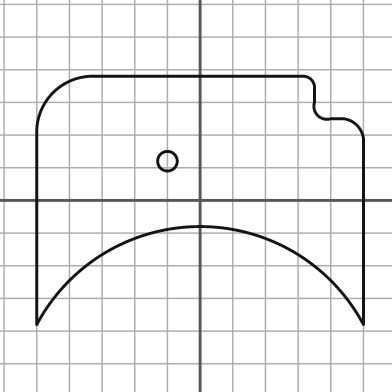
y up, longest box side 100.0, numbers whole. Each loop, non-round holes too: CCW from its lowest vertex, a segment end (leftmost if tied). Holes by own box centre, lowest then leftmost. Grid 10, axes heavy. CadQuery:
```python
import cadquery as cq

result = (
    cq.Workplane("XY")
    .moveTo(-50.0, -38.0)
    .threePointArc((0.0, -8.0), (50.0, -38.0))
    .lineTo(50.0, 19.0)
    .threePointArc((48.0, 23.0), (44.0, 25.0))
    .lineTo(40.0, 25.0)
    .threePointArc((36.0, 26.0), (35.0, 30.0))
    .lineTo(35.0, 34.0)
    .threePointArc((34.0, 37.0), (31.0, 38.0))
    .lineTo(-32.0, 38.0)
    .threePointArc((-45.0, 33.0), (-50.0, 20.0))
    .close()
    .moveTo(-10.0, 12.0)
    .circle(3.0)
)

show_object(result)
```